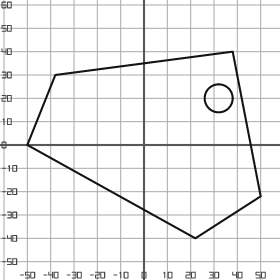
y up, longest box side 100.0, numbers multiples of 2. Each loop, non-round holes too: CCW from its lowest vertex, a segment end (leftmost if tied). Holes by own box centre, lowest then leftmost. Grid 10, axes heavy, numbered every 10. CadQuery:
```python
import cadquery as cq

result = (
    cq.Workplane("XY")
    .moveTo(22.0, -40.0)
    .lineTo(50.0, -22.0)
    .lineTo(38.0, 40.0)
    .lineTo(-38.0, 30.0)
    .lineTo(-50.0, 0.0)
    .close()
    .moveTo(32.0, 20.0)
    .circle(6.0)
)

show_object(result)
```